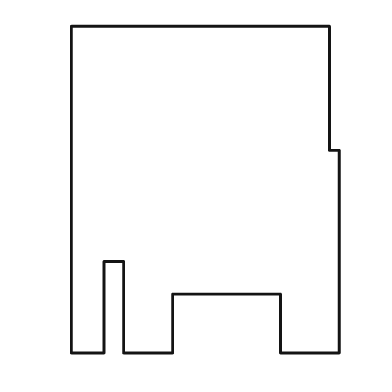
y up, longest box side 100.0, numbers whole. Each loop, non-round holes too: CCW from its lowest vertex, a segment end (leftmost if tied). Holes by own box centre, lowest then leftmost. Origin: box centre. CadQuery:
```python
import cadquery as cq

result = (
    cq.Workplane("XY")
    .moveTo(-41.0, -50.0)
    .lineTo(-31.0, -50.0)
    .lineTo(-31.0, -22.0)
    .lineTo(-25.0, -22.0)
    .lineTo(-25.0, -50.0)
    .lineTo(-10.0, -50.0)
    .lineTo(-10.0, -32.0)
    .lineTo(23.0, -32.0)
    .lineTo(23.0, -50.0)
    .lineTo(41.0, -50.0)
    .lineTo(41.0, 12.0)
    .lineTo(38.0, 12.0)
    .lineTo(38.0, 50.0)
    .lineTo(-41.0, 50.0)
    .close()
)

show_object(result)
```